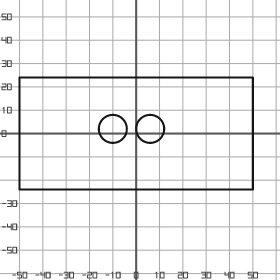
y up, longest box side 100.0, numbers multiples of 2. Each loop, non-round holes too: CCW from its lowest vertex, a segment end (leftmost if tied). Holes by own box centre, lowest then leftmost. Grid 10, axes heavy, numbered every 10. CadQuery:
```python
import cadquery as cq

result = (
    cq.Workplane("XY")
    .moveTo(-50.0, -24.0)
    .lineTo(50.0, -24.0)
    .lineTo(50.0, 24.0)
    .lineTo(-50.0, 24.0)
    .close()
    .moveTo(-10.0, 2.0)
    .circle(6.0)
    .moveTo(6.0, 2.0)
    .circle(6.0)
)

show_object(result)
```